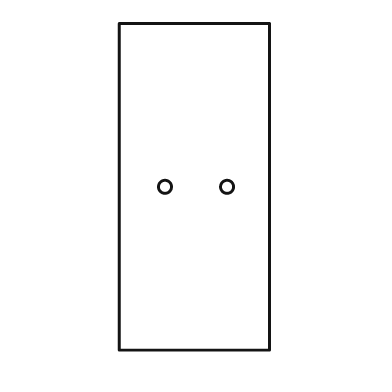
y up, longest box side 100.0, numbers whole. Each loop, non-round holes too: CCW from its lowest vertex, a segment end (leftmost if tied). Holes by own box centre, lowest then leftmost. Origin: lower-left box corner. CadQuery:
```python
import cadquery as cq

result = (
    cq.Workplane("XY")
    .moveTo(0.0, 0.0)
    .lineTo(46.0, 0.0)
    .lineTo(46.0, 100.0)
    .lineTo(0.0, 100.0)
    .close()
    .moveTo(14.0, 50.0)
    .circle(2.0)
    .moveTo(33.0, 50.0)
    .circle(2.0)
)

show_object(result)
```